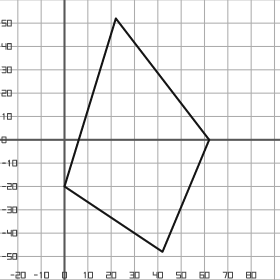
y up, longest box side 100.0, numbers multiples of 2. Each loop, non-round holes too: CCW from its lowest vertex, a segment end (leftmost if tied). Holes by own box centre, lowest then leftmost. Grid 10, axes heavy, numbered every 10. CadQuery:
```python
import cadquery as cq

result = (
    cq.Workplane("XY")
    .moveTo(42.0, -48.0)
    .lineTo(62.0, 0.0)
    .lineTo(22.0, 52.0)
    .lineTo(0.0, -20.0)
    .close()
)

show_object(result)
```